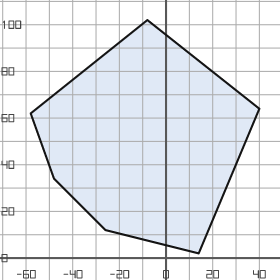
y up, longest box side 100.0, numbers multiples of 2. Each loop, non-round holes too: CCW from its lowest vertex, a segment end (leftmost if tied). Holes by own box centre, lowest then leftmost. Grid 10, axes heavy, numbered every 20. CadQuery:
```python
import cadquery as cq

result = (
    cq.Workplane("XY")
    .moveTo(14.0, 2.0)
    .lineTo(40.0, 64.0)
    .lineTo(-8.0, 102.0)
    .lineTo(-58.0, 62.0)
    .lineTo(-48.0, 34.0)
    .lineTo(-26.0, 12.0)
    .close()
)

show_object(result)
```